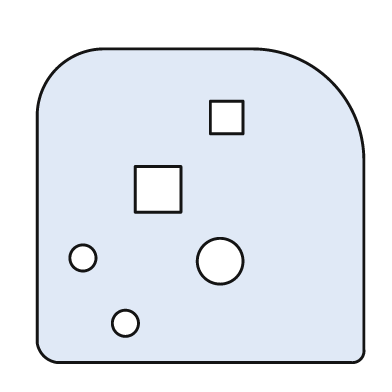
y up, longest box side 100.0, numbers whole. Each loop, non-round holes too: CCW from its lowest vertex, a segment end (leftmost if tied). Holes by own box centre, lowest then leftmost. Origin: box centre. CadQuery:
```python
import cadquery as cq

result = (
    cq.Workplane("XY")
    .moveTo(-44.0, -48.0)
    .lineTo(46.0, -48.0)
    .threePointArc((49.0, -47.0), (50.0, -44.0))
    .lineTo(50.0, 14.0)
    .threePointArc((40.0, 38.0), (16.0, 48.0))
    .lineTo(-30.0, 48.0)
    .threePointArc((-44.0, 42.0), (-50.0, 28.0))
    .lineTo(-50.0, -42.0)
    .threePointArc((-48.0, -46.0), (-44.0, -48.0))
    .close()
    .moveTo(-23.0, -36.0)
    .circle(4.0)
    .moveTo(6.0, -17.0)
    .circle(7.0)
    .moveTo(-36.0, -16.0)
    .circle(4.0)
    .moveTo(-20.0, -2.0)
    .lineTo(-6.0, -2.0)
    .lineTo(-6.0, 12.0)
    .lineTo(-20.0, 12.0)
    .close()
    .moveTo(3.0, 22.0)
    .lineTo(13.0, 22.0)
    .lineTo(13.0, 32.0)
    .lineTo(3.0, 32.0)
    .close()
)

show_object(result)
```